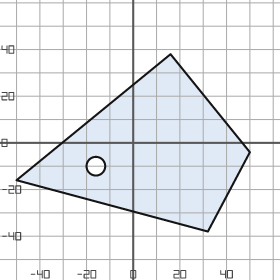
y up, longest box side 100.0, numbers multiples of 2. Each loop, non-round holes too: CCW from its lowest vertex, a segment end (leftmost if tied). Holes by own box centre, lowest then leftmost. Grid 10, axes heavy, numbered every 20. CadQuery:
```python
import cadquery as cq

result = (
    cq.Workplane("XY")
    .moveTo(32.0, -38.0)
    .lineTo(50.0, -4.0)
    .lineTo(16.0, 38.0)
    .lineTo(-50.0, -16.0)
    .close()
    .moveTo(-16.0, -10.0)
    .circle(4.0)
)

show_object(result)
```